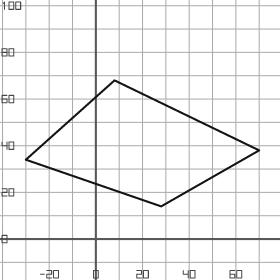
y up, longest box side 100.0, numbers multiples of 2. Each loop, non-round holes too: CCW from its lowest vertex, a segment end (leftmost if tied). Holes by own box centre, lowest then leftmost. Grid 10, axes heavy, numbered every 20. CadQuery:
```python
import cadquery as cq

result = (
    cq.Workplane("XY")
    .moveTo(28.0, 14.0)
    .lineTo(70.0, 38.0)
    .lineTo(8.0, 68.0)
    .lineTo(-30.0, 34.0)
    .close()
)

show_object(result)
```